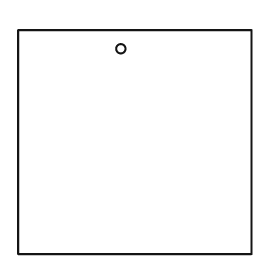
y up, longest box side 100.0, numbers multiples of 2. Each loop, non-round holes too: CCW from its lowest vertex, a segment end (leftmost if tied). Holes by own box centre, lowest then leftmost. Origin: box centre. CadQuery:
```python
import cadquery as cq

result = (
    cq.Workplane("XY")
    .moveTo(-50.0, -48.0)
    .lineTo(50.0, -48.0)
    .lineTo(50.0, 48.0)
    .lineTo(-50.0, 48.0)
    .close()
    .moveTo(-6.0, 40.0)
    .circle(2.0)
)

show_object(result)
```